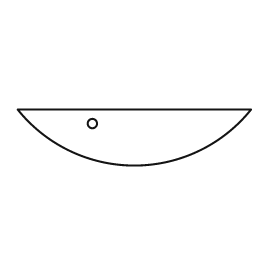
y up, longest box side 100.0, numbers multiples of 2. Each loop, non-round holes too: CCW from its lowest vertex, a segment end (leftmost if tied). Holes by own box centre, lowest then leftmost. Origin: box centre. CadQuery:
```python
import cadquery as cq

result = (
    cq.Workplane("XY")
    .moveTo(-50.0, 12.0)
    .threePointArc((0.0, -12.0), (50.0, 12.0))
    .close()
    .moveTo(-18.0, 6.0)
    .circle(2.0)
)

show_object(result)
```